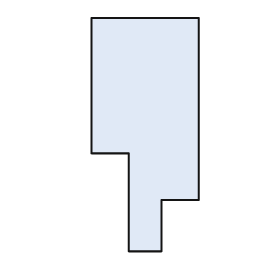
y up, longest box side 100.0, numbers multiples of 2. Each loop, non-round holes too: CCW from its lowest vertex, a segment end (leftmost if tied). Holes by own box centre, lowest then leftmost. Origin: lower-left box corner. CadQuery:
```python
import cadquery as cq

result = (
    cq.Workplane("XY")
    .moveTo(16.0, 0.0)
    .lineTo(30.0, 0.0)
    .lineTo(30.0, 22.0)
    .lineTo(46.0, 22.0)
    .lineTo(46.0, 100.0)
    .lineTo(0.0, 100.0)
    .lineTo(0.0, 42.0)
    .lineTo(16.0, 42.0)
    .close()
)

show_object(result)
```